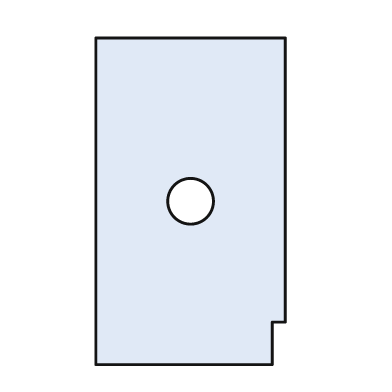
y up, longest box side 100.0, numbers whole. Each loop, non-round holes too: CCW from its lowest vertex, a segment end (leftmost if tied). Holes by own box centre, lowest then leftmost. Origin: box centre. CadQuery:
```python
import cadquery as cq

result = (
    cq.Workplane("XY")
    .moveTo(-29.0, -50.0)
    .lineTo(25.0, -50.0)
    .lineTo(25.0, -37.0)
    .lineTo(29.0, -37.0)
    .lineTo(29.0, 50.0)
    .lineTo(-29.0, 50.0)
    .close()
    .moveTo(0.0, 0.0)
    .circle(7.0)
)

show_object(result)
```